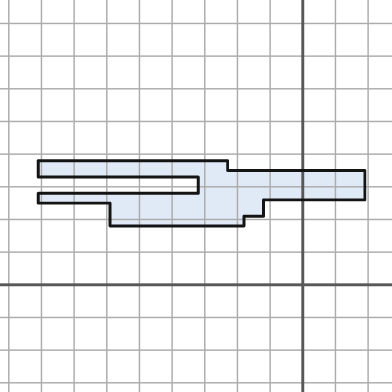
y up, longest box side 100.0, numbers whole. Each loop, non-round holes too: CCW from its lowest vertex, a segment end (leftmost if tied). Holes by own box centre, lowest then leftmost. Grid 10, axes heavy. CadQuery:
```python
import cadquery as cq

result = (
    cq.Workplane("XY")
    .moveTo(-59.0, 18.0)
    .lineTo(-18.0, 18.0)
    .lineTo(-18.0, 21.0)
    .lineTo(-12.0, 21.0)
    .lineTo(-12.0, 26.0)
    .lineTo(19.0, 26.0)
    .lineTo(19.0, 35.0)
    .lineTo(-23.0, 35.0)
    .lineTo(-23.0, 38.0)
    .lineTo(-81.0, 38.0)
    .lineTo(-81.0, 33.0)
    .lineTo(-32.0, 33.0)
    .lineTo(-32.0, 28.0)
    .lineTo(-81.0, 28.0)
    .lineTo(-81.0, 25.0)
    .lineTo(-59.0, 25.0)
    .close()
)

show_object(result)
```